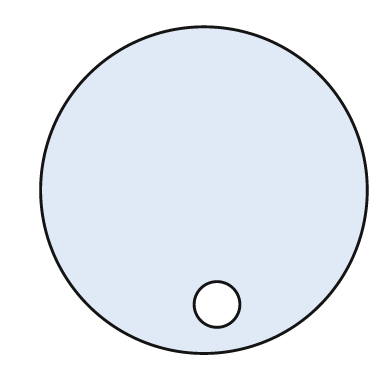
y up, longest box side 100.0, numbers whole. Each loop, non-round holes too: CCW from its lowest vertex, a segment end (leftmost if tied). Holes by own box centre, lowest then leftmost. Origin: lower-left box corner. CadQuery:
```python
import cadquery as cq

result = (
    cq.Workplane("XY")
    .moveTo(50.0, 50.0)
    .circle(50.0)
    .moveTo(54.0, 15.0)
    .circle(7.0)
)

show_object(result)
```